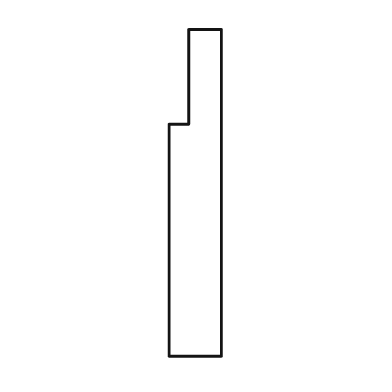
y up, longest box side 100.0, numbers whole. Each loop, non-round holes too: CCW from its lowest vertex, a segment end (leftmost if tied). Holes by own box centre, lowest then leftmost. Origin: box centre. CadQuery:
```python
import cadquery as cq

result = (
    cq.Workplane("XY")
    .moveTo(-8.0, -50.0)
    .lineTo(8.0, -50.0)
    .lineTo(8.0, 50.0)
    .lineTo(-2.0, 50.0)
    .lineTo(-2.0, 21.0)
    .lineTo(-8.0, 21.0)
    .close()
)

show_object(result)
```